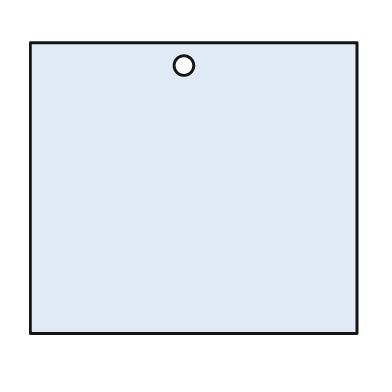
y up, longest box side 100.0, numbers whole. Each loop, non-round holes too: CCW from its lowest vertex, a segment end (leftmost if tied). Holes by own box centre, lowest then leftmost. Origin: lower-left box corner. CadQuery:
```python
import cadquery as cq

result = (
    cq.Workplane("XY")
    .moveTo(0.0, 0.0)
    .lineTo(100.0, 0.0)
    .lineTo(100.0, 89.0)
    .lineTo(0.0, 89.0)
    .close()
    .moveTo(47.0, 82.0)
    .circle(3.0)
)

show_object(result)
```